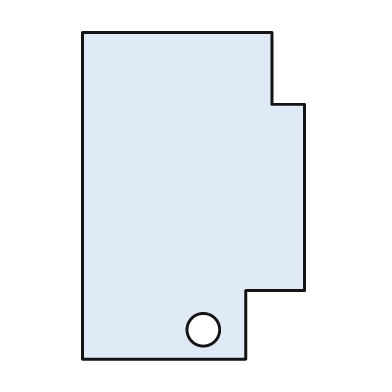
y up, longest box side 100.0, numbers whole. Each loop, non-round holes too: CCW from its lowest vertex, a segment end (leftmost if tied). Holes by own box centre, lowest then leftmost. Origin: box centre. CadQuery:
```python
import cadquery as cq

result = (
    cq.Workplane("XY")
    .moveTo(-34.0, -50.0)
    .lineTo(16.0, -50.0)
    .lineTo(16.0, -29.0)
    .lineTo(34.0, -29.0)
    .lineTo(34.0, 28.0)
    .lineTo(24.0, 28.0)
    .lineTo(24.0, 50.0)
    .lineTo(-34.0, 50.0)
    .close()
    .moveTo(3.0, -41.0)
    .circle(5.0)
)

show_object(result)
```